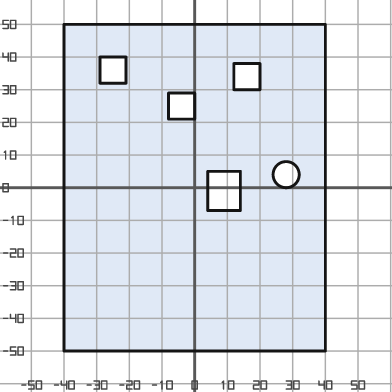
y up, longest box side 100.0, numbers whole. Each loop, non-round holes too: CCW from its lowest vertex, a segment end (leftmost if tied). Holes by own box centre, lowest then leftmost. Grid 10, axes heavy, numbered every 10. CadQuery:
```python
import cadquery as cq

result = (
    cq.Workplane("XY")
    .moveTo(-40.0, -50.0)
    .lineTo(40.0, -50.0)
    .lineTo(40.0, 50.0)
    .lineTo(-40.0, 50.0)
    .close()
    .moveTo(4.0, -7.0)
    .lineTo(14.0, -7.0)
    .lineTo(14.0, 5.0)
    .lineTo(4.0, 5.0)
    .close()
    .moveTo(28.0, 4.0)
    .circle(4.0)
    .moveTo(-8.0, 21.0)
    .lineTo(0.0, 21.0)
    .lineTo(0.0, 29.0)
    .lineTo(-8.0, 29.0)
    .close()
    .moveTo(12.0, 30.0)
    .lineTo(20.0, 30.0)
    .lineTo(20.0, 38.0)
    .lineTo(12.0, 38.0)
    .close()
    .moveTo(-29.0, 32.0)
    .lineTo(-21.0, 32.0)
    .lineTo(-21.0, 40.0)
    .lineTo(-29.0, 40.0)
    .close()
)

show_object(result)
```